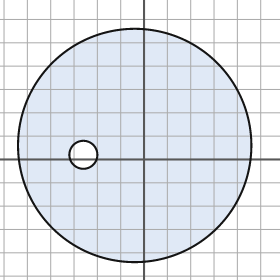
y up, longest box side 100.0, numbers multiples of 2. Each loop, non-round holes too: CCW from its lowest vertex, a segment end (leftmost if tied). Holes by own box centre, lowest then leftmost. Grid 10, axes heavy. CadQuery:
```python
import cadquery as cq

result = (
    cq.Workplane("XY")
    .moveTo(-4.0, 6.0)
    .circle(50.0)
    .moveTo(-26.0, 2.0)
    .circle(6.0)
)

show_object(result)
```